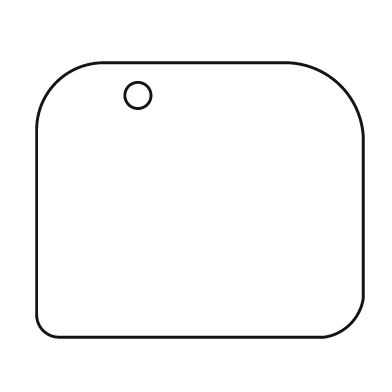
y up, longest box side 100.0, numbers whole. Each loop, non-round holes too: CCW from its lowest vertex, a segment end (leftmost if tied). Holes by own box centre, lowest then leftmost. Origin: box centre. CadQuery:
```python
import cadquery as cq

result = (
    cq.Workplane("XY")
    .moveTo(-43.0, -42.0)
    .lineTo(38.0, -42.0)
    .threePointArc((46.0, -38.0), (50.0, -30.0))
    .lineTo(50.0, 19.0)
    .threePointArc((43.0, 35.0), (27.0, 42.0))
    .lineTo(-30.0, 42.0)
    .threePointArc((-44.0, 36.0), (-50.0, 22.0))
    .lineTo(-50.0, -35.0)
    .threePointArc((-48.0, -40.0), (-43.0, -42.0))
    .close()
    .moveTo(-19.0, 32.0)
    .circle(4.0)
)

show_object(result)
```